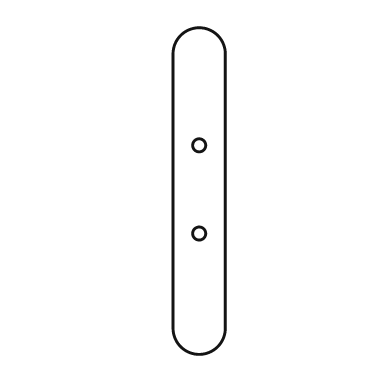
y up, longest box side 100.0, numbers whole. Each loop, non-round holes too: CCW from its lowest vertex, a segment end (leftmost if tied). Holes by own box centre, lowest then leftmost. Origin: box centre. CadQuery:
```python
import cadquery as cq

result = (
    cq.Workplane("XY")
    .moveTo(-8.0, -42.0)
    .threePointArc((0.0, -50.0), (8.0, -42.0))
    .lineTo(8.0, 42.0)
    .threePointArc((0.0, 50.0), (-8.0, 42.0))
    .close()
    .moveTo(0.0, -13.0)
    .circle(2.0)
    .moveTo(0.0, 14.0)
    .circle(2.0)
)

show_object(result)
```